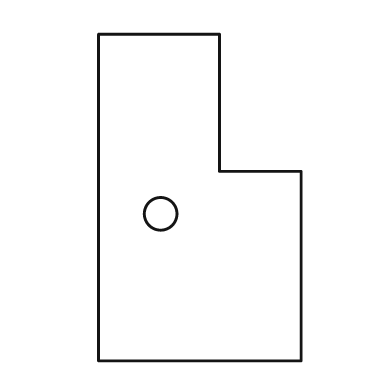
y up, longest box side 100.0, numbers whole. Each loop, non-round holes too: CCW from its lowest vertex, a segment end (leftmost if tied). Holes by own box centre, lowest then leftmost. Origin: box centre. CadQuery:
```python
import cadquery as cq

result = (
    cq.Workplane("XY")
    .moveTo(-31.0, -50.0)
    .lineTo(31.0, -50.0)
    .lineTo(31.0, 8.0)
    .lineTo(6.0, 8.0)
    .lineTo(6.0, 50.0)
    .lineTo(-31.0, 50.0)
    .close()
    .moveTo(-12.0, -5.0)
    .circle(5.0)
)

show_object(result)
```